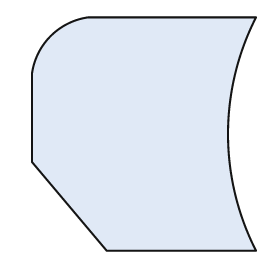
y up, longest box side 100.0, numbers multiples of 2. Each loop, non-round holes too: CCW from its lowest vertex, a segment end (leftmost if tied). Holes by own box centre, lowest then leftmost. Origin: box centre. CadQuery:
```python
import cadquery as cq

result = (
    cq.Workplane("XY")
    .moveTo(-16.0, -50.0)
    .lineTo(48.0, -50.0)
    .threePointArc((36.0, 0.0), (48.0, 50.0))
    .lineTo(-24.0, 50.0)
    .threePointArc((-40.0, 42.0), (-48.0, 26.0))
    .lineTo(-48.0, -12.0)
    .close()
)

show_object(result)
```